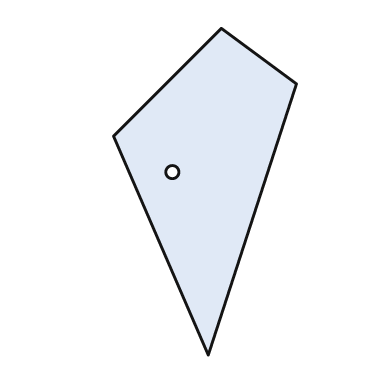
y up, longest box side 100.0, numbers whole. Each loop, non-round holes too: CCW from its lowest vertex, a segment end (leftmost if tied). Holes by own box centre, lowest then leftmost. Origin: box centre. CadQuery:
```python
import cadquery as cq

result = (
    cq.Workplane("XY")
    .moveTo(1.0, -50.0)
    .lineTo(28.0, 33.0)
    .lineTo(5.0, 50.0)
    .lineTo(-28.0, 17.0)
    .close()
    .moveTo(-10.0, 6.0)
    .circle(2.0)
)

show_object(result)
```